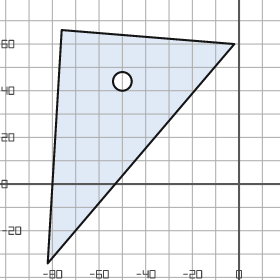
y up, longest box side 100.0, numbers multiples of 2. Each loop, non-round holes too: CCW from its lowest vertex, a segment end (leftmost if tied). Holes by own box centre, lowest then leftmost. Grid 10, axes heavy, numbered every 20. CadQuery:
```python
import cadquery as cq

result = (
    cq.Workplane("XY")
    .moveTo(-82.0, -34.0)
    .lineTo(-2.0, 60.0)
    .lineTo(-76.0, 66.0)
    .close()
    .moveTo(-50.0, 44.0)
    .circle(4.0)
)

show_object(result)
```